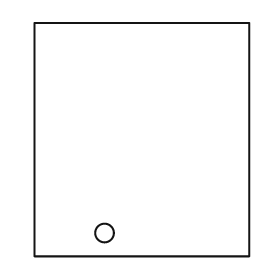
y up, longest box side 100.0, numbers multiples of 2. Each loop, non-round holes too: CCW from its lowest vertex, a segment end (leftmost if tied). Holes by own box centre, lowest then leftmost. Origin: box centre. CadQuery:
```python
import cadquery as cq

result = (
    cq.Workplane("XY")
    .moveTo(-46.0, -50.0)
    .lineTo(46.0, -50.0)
    .lineTo(46.0, 50.0)
    .lineTo(-46.0, 50.0)
    .close()
    .moveTo(-16.0, -40.0)
    .circle(4.0)
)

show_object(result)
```